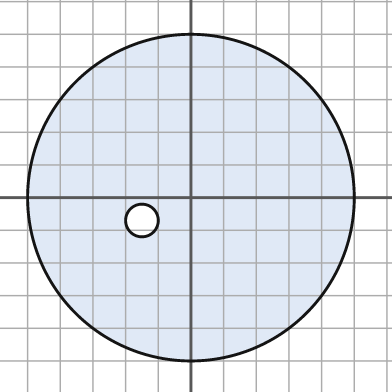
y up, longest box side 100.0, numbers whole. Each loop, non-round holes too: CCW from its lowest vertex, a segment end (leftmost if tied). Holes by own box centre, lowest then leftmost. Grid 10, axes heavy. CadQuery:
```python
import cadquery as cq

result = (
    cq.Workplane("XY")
    .moveTo(0.0, 0.0)
    .circle(50.0)
    .moveTo(-15.0, -7.0)
    .circle(5.0)
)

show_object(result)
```